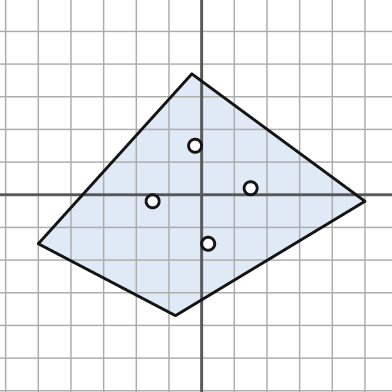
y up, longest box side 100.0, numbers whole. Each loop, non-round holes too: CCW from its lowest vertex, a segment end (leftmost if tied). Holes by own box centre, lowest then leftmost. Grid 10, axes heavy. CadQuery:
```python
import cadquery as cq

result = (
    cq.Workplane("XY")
    .moveTo(-8.0, -37.0)
    .lineTo(50.0, -2.0)
    .lineTo(-3.0, 37.0)
    .lineTo(-50.0, -15.0)
    .close()
    .moveTo(2.0, -15.0)
    .circle(2.0)
    .moveTo(-15.0, -2.0)
    .circle(2.0)
    .moveTo(15.0, 2.0)
    .circle(2.0)
    .moveTo(-2.0, 15.0)
    .circle(2.0)
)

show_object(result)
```